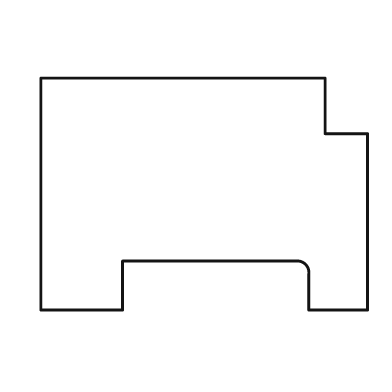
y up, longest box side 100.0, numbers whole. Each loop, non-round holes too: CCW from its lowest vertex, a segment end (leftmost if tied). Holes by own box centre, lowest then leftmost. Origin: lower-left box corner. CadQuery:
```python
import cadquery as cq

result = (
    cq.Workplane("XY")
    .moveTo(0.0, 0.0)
    .lineTo(25.0, 0.0)
    .lineTo(25.0, 15.0)
    .lineTo(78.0, 15.0)
    .threePointArc((81.0, 14.0), (82.0, 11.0))
    .lineTo(82.0, 0.0)
    .lineTo(100.0, 0.0)
    .lineTo(100.0, 54.0)
    .lineTo(87.0, 54.0)
    .lineTo(87.0, 71.0)
    .lineTo(0.0, 71.0)
    .close()
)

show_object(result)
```